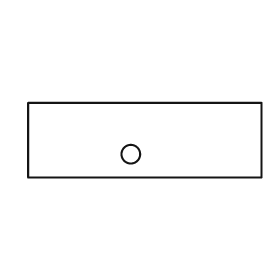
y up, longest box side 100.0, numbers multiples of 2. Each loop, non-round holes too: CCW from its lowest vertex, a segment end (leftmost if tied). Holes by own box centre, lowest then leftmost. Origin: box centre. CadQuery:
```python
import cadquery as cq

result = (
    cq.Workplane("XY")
    .moveTo(-50.0, -16.0)
    .lineTo(50.0, -16.0)
    .lineTo(50.0, 16.0)
    .lineTo(-50.0, 16.0)
    .close()
    .moveTo(-6.0, -6.0)
    .circle(4.0)
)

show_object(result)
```